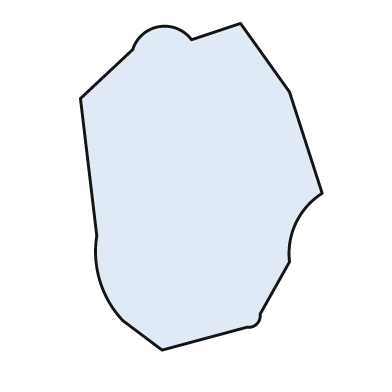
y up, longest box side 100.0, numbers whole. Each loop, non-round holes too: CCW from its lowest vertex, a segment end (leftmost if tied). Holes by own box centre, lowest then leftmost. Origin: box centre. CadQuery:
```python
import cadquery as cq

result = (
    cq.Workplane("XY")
    .moveTo(-12.0, -50.0)
    .lineTo(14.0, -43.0)
    .threePointArc((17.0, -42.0), (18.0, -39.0))
    .lineTo(27.0, -23.0)
    .threePointArc((29.0, -11.0), (37.0, -2.0))
    .lineTo(27.0, 29.0)
    .lineTo(12.0, 50.0)
    .lineTo(-3.0, 45.0)
    .threePointArc((-13.0, 49.0), (-21.0, 42.0))
    .lineTo(-37.0, 27.0)
    .lineTo(-32.0, -15.0)
    .threePointArc((-31.0, -29.0), (-24.0, -41.0))
    .close()
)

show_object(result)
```